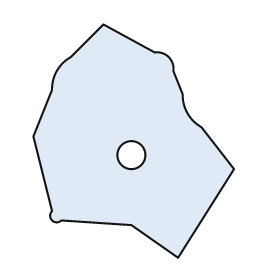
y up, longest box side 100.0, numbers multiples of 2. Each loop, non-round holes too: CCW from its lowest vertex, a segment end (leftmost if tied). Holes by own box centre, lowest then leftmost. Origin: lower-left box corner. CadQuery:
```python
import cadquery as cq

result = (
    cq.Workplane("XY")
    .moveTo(62.0, 0.0)
    .lineTo(86.0, 38.0)
    .lineTo(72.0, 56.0)
    .threePointArc((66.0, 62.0), (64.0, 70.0))
    .lineTo(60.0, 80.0)
    .threePointArc((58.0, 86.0), (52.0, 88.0))
    .lineTo(30.0, 100.0)
    .lineTo(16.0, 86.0)
    .threePointArc((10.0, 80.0), (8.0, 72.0))
    .lineTo(0.0, 52.0)
    .lineTo(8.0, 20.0)
    .threePointArc((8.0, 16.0), (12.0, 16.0))
    .lineTo(42.0, 14.0)
    .close()
    .moveTo(42.0, 44.0)
    .circle(6.0)
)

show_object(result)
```